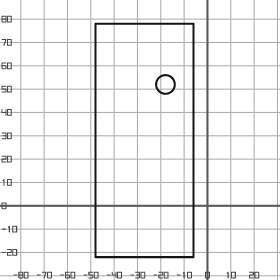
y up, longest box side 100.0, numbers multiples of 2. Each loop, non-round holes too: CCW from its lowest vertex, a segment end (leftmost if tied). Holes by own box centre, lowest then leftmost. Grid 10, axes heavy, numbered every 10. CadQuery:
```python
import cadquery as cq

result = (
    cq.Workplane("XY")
    .moveTo(-48.0, -22.0)
    .lineTo(-6.0, -22.0)
    .lineTo(-6.0, 78.0)
    .lineTo(-48.0, 78.0)
    .close()
    .moveTo(-18.0, 52.0)
    .circle(4.0)
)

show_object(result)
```